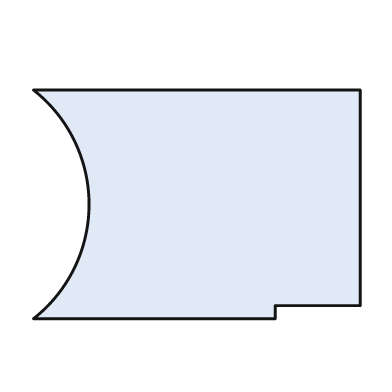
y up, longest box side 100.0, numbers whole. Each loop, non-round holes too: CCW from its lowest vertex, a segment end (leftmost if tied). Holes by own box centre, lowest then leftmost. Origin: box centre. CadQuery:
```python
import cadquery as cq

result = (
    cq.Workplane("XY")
    .moveTo(-50.0, -35.0)
    .lineTo(24.0, -35.0)
    .lineTo(24.0, -31.0)
    .lineTo(50.0, -31.0)
    .lineTo(50.0, 35.0)
    .lineTo(-50.0, 35.0)
    .threePointArc((-33.0, 0.0), (-50.0, -35.0))
    .close()
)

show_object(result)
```